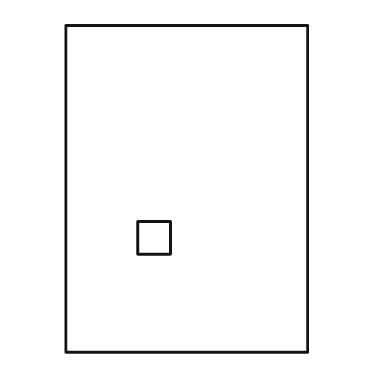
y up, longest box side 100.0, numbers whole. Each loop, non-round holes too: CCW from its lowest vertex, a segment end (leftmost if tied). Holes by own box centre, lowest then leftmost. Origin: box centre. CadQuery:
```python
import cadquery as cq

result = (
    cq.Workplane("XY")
    .moveTo(-37.0, -50.0)
    .lineTo(37.0, -50.0)
    .lineTo(37.0, 50.0)
    .lineTo(-37.0, 50.0)
    .close()
    .moveTo(-15.0, -20.0)
    .lineTo(-5.0, -20.0)
    .lineTo(-5.0, -10.0)
    .lineTo(-15.0, -10.0)
    .close()
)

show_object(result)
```